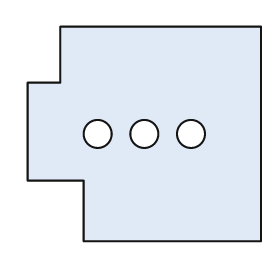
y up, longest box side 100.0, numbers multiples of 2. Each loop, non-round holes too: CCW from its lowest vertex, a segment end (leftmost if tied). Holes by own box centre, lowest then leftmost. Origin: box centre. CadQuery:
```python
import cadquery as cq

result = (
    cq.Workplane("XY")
    .moveTo(-26.0, -46.0)
    .lineTo(50.0, -46.0)
    .lineTo(50.0, 46.0)
    .lineTo(-36.0, 46.0)
    .lineTo(-36.0, 22.0)
    .lineTo(-50.0, 22.0)
    .lineTo(-50.0, -20.0)
    .lineTo(-26.0, -20.0)
    .close()
    .moveTo(-20.0, 0.0)
    .circle(6.0)
    .moveTo(0.0, 0.0)
    .circle(6.0)
    .moveTo(20.0, 0.0)
    .circle(6.0)
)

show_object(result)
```